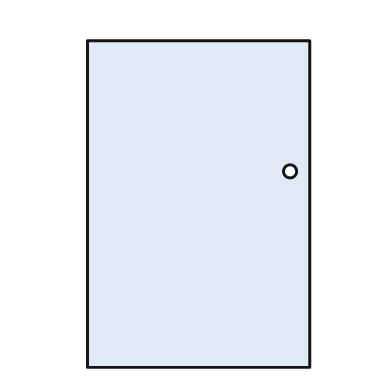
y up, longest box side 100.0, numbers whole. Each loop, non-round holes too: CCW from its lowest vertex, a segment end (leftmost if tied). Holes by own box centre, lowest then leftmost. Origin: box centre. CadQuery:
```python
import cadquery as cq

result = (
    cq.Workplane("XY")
    .moveTo(-34.0, -50.0)
    .lineTo(34.0, -50.0)
    .lineTo(34.0, 50.0)
    .lineTo(-34.0, 50.0)
    .close()
    .moveTo(28.0, 10.0)
    .circle(2.0)
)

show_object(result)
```